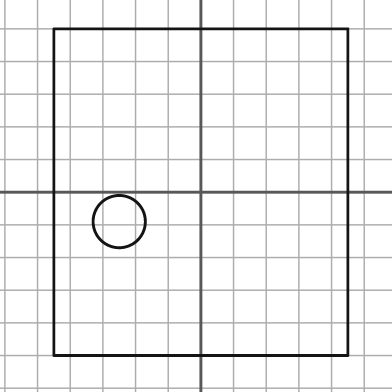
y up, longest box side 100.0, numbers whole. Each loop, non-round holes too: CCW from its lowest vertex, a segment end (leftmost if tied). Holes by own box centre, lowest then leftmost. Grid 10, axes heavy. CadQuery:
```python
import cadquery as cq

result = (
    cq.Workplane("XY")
    .moveTo(-45.0, -50.0)
    .lineTo(45.0, -50.0)
    .lineTo(45.0, 50.0)
    .lineTo(-45.0, 50.0)
    .close()
    .moveTo(-25.0, -9.0)
    .circle(8.0)
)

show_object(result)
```